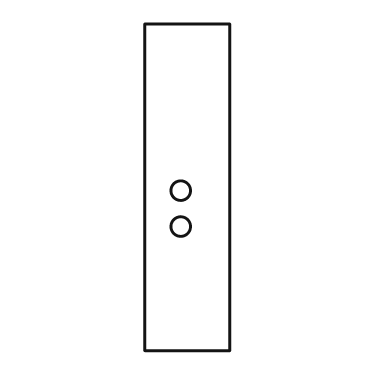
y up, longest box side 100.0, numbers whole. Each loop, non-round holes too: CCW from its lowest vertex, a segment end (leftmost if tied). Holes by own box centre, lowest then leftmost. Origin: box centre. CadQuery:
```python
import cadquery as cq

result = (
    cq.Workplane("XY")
    .moveTo(-13.0, -50.0)
    .lineTo(13.0, -50.0)
    .lineTo(13.0, 50.0)
    .lineTo(-13.0, 50.0)
    .close()
    .moveTo(-2.0, -12.0)
    .circle(3.0)
    .moveTo(-2.0, -1.0)
    .circle(3.0)
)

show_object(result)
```